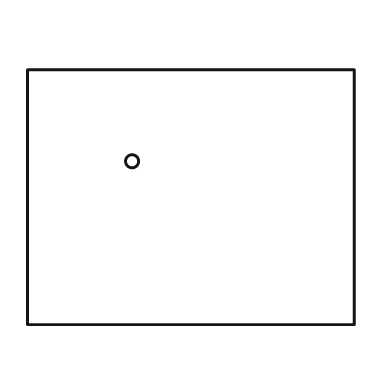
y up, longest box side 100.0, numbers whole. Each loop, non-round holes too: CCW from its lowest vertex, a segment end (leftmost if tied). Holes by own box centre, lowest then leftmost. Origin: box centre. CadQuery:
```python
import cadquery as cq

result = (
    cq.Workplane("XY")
    .moveTo(-50.0, -39.0)
    .lineTo(50.0, -39.0)
    .lineTo(50.0, 39.0)
    .lineTo(-50.0, 39.0)
    .close()
    .moveTo(-18.0, 11.0)
    .circle(2.0)
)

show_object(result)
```